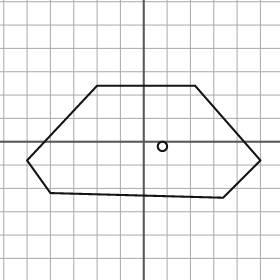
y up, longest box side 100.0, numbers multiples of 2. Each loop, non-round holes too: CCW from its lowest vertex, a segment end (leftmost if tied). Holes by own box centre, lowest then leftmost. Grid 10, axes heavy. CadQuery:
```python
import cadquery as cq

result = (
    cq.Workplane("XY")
    .moveTo(34.0, -24.0)
    .lineTo(50.0, -8.0)
    .lineTo(22.0, 24.0)
    .lineTo(-20.0, 24.0)
    .lineTo(-50.0, -8.0)
    .lineTo(-40.0, -22.0)
    .close()
    .moveTo(8.0, -2.0)
    .circle(2.0)
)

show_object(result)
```